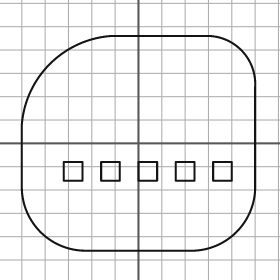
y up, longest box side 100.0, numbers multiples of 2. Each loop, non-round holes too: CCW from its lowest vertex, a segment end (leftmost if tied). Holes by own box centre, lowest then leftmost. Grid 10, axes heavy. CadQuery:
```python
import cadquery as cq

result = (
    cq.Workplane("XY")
    .moveTo(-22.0, -46.0)
    .lineTo(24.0, -46.0)
    .threePointArc((42.0, -38.0), (50.0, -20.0))
    .lineTo(50.0, 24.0)
    .threePointArc((44.0, 40.0), (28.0, 46.0))
    .lineTo(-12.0, 46.0)
    .threePointArc((-38.0, 34.0), (-50.0, 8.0))
    .lineTo(-50.0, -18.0)
    .threePointArc((-42.0, -38.0), (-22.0, -46.0))
    .close()
    .moveTo(-32.0, -16.0)
    .lineTo(-24.0, -16.0)
    .lineTo(-24.0, -8.0)
    .lineTo(-32.0, -8.0)
    .close()
    .moveTo(-16.0, -16.0)
    .lineTo(-8.0, -16.0)
    .lineTo(-8.0, -8.0)
    .lineTo(-16.0, -8.0)
    .close()
    .moveTo(0.0, -16.0)
    .lineTo(8.0, -16.0)
    .lineTo(8.0, -8.0)
    .lineTo(0.0, -8.0)
    .close()
    .moveTo(16.0, -16.0)
    .lineTo(24.0, -16.0)
    .lineTo(24.0, -8.0)
    .lineTo(16.0, -8.0)
    .close()
    .moveTo(32.0, -16.0)
    .lineTo(40.0, -16.0)
    .lineTo(40.0, -8.0)
    .lineTo(32.0, -8.0)
    .close()
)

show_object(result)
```